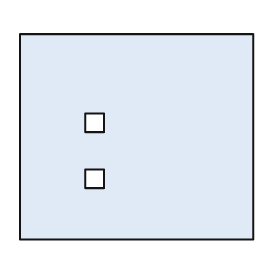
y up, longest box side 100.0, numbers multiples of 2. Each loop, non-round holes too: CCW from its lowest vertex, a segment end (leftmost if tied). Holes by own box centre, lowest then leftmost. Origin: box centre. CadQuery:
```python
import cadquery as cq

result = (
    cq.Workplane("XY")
    .moveTo(-50.0, -44.0)
    .lineTo(50.0, -44.0)
    .lineTo(50.0, 44.0)
    .lineTo(-50.0, 44.0)
    .close()
    .moveTo(-22.0, -22.0)
    .lineTo(-14.0, -22.0)
    .lineTo(-14.0, -14.0)
    .lineTo(-22.0, -14.0)
    .close()
    .moveTo(-22.0, 2.0)
    .lineTo(-14.0, 2.0)
    .lineTo(-14.0, 10.0)
    .lineTo(-22.0, 10.0)
    .close()
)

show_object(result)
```